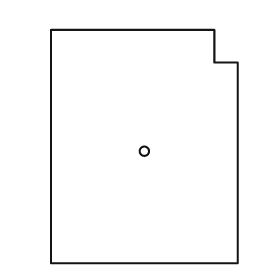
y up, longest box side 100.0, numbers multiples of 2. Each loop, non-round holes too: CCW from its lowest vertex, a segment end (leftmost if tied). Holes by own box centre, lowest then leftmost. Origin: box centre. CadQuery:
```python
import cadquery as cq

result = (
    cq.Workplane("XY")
    .moveTo(-40.0, -50.0)
    .lineTo(40.0, -50.0)
    .lineTo(40.0, 36.0)
    .lineTo(30.0, 36.0)
    .lineTo(30.0, 50.0)
    .lineTo(-40.0, 50.0)
    .close()
    .moveTo(0.0, -2.0)
    .circle(2.0)
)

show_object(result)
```